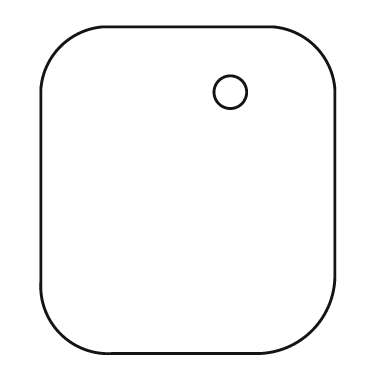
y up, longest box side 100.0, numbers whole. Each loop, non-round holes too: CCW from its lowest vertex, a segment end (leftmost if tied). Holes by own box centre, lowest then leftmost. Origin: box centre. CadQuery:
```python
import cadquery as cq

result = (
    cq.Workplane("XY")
    .moveTo(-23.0, -50.0)
    .lineTo(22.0, -50.0)
    .threePointArc((38.0, -43.0), (45.0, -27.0))
    .lineTo(45.0, 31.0)
    .threePointArc((39.0, 44.0), (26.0, 50.0))
    .lineTo(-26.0, 50.0)
    .threePointArc((-39.0, 44.0), (-45.0, 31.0))
    .lineTo(-45.0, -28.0)
    .threePointArc((-39.0, -44.0), (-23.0, -50.0))
    .close()
    .moveTo(13.0, 30.0)
    .circle(5.0)
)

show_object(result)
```